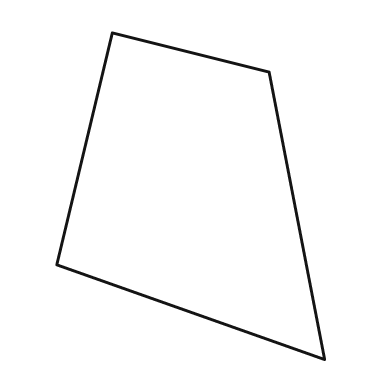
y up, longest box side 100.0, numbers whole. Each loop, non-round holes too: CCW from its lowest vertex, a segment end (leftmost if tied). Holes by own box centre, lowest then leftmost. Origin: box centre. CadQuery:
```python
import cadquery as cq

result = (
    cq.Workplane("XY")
    .moveTo(41.0, -50.0)
    .lineTo(24.0, 38.0)
    .lineTo(-24.0, 50.0)
    .lineTo(-41.0, -21.0)
    .close()
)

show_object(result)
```